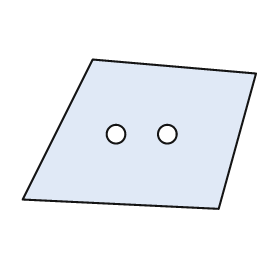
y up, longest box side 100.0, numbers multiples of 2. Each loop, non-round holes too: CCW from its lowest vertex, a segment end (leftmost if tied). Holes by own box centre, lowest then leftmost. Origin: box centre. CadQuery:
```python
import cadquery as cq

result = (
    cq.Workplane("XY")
    .moveTo(34.0, -32.0)
    .lineTo(50.0, 26.0)
    .lineTo(-20.0, 32.0)
    .lineTo(-50.0, -28.0)
    .close()
    .moveTo(-10.0, 0.0)
    .circle(4.0)
    .moveTo(12.0, 0.0)
    .circle(4.0)
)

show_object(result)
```